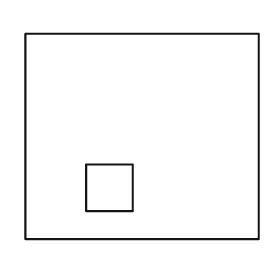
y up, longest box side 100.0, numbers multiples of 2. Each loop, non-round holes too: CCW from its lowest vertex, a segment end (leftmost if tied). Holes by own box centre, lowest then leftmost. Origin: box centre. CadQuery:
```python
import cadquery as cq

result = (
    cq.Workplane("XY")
    .moveTo(-50.0, -44.0)
    .lineTo(50.0, -44.0)
    .lineTo(50.0, 44.0)
    .lineTo(-50.0, 44.0)
    .close()
    .moveTo(-24.0, -32.0)
    .lineTo(-4.0, -32.0)
    .lineTo(-4.0, -12.0)
    .lineTo(-24.0, -12.0)
    .close()
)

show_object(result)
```